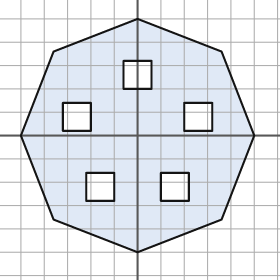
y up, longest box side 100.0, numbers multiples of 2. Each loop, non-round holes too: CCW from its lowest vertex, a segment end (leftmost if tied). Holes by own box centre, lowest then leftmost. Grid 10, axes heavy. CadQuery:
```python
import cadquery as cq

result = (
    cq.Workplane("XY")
    .moveTo(0.0, -50.0)
    .lineTo(36.0, -36.0)
    .lineTo(50.0, 0.0)
    .lineTo(36.0, 36.0)
    .lineTo(0.0, 50.0)
    .lineTo(-36.0, 36.0)
    .lineTo(-50.0, 0.0)
    .lineTo(-36.0, -36.0)
    .close()
    .moveTo(-22.0, -28.0)
    .lineTo(-10.0, -28.0)
    .lineTo(-10.0, -16.0)
    .lineTo(-22.0, -16.0)
    .close()
    .moveTo(10.0, -28.0)
    .lineTo(22.0, -28.0)
    .lineTo(22.0, -16.0)
    .lineTo(10.0, -16.0)
    .close()
    .moveTo(-32.0, 2.0)
    .lineTo(-20.0, 2.0)
    .lineTo(-20.0, 14.0)
    .lineTo(-32.0, 14.0)
    .close()
    .moveTo(20.0, 2.0)
    .lineTo(32.0, 2.0)
    .lineTo(32.0, 14.0)
    .lineTo(20.0, 14.0)
    .close()
    .moveTo(-6.0, 20.0)
    .lineTo(6.0, 20.0)
    .lineTo(6.0, 32.0)
    .lineTo(-6.0, 32.0)
    .close()
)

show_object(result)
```